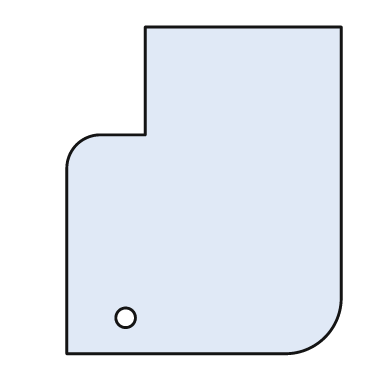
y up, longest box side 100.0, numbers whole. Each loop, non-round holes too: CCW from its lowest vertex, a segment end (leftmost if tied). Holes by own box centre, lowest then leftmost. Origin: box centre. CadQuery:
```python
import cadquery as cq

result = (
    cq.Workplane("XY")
    .moveTo(-42.0, -50.0)
    .lineTo(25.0, -50.0)
    .threePointArc((37.0, -45.0), (42.0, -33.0))
    .lineTo(42.0, 50.0)
    .lineTo(-18.0, 50.0)
    .lineTo(-18.0, 17.0)
    .lineTo(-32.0, 17.0)
    .threePointArc((-39.0, 14.0), (-42.0, 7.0))
    .close()
    .moveTo(-24.0, -39.0)
    .circle(3.0)
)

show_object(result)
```